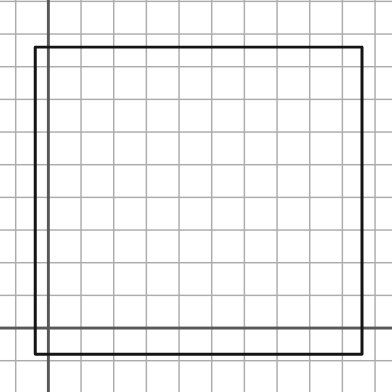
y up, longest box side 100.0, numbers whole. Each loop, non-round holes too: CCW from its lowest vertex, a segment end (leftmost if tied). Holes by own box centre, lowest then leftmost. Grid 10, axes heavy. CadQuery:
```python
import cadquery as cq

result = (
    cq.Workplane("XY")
    .moveTo(-4.0, -8.0)
    .lineTo(96.0, -8.0)
    .lineTo(96.0, 86.0)
    .lineTo(-4.0, 86.0)
    .close()
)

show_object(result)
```